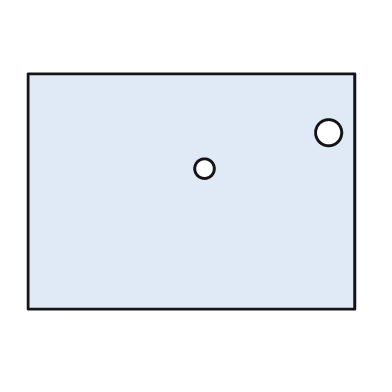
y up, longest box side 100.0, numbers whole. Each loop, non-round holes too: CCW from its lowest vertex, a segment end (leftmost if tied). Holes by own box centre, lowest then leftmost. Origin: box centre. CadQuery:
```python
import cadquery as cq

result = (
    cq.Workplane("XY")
    .moveTo(-50.0, -36.0)
    .lineTo(50.0, -36.0)
    .lineTo(50.0, 36.0)
    .lineTo(-50.0, 36.0)
    .close()
    .moveTo(4.0, 7.0)
    .circle(3.0)
    .moveTo(42.0, 18.0)
    .circle(4.0)
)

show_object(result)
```